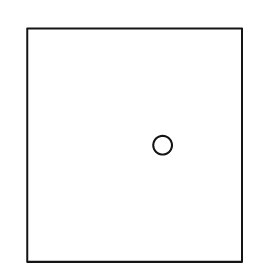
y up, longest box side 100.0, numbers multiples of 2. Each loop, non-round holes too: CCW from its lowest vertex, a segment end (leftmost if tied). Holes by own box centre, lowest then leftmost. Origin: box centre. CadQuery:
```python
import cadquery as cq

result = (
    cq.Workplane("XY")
    .moveTo(-46.0, -50.0)
    .lineTo(46.0, -50.0)
    .lineTo(46.0, 50.0)
    .lineTo(-46.0, 50.0)
    .close()
    .moveTo(12.0, 0.0)
    .circle(4.0)
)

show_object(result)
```